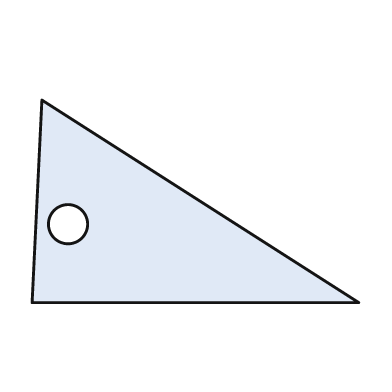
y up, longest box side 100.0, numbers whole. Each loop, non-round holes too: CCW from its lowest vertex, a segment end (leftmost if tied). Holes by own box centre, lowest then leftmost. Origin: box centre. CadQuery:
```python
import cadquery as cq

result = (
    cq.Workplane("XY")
    .moveTo(-50.0, -31.0)
    .lineTo(50.0, -31.0)
    .lineTo(-47.0, 31.0)
    .close()
    .moveTo(-39.0, -7.0)
    .circle(6.0)
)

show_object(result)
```